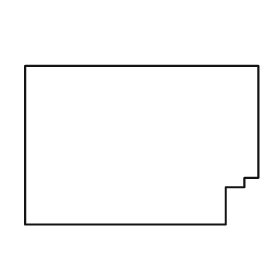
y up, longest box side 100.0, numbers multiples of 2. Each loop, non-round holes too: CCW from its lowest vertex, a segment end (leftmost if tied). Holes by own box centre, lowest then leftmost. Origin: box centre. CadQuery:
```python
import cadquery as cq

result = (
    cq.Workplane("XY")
    .moveTo(-50.0, -34.0)
    .lineTo(36.0, -34.0)
    .lineTo(36.0, -18.0)
    .lineTo(44.0, -18.0)
    .lineTo(44.0, -14.0)
    .lineTo(50.0, -14.0)
    .lineTo(50.0, 34.0)
    .lineTo(-50.0, 34.0)
    .close()
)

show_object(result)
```